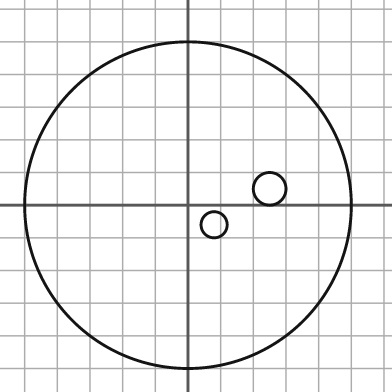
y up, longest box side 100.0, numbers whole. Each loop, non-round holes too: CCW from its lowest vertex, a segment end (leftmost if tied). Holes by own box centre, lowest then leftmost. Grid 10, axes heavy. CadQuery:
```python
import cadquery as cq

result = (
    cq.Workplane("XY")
    .moveTo(0.0, 0.0)
    .circle(50.0)
    .moveTo(8.0, -6.0)
    .circle(4.0)
    .moveTo(25.0, 5.0)
    .circle(5.0)
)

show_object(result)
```